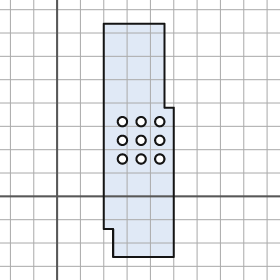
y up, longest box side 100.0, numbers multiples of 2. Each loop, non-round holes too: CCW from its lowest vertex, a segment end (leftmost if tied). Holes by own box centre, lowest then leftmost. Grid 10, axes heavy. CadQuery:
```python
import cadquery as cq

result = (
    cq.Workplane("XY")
    .moveTo(24.0, -26.0)
    .lineTo(50.0, -26.0)
    .lineTo(50.0, 38.0)
    .lineTo(46.0, 38.0)
    .lineTo(46.0, 74.0)
    .lineTo(20.0, 74.0)
    .lineTo(20.0, -14.0)
    .lineTo(24.0, -14.0)
    .close()
    .moveTo(28.0, 16.0)
    .circle(2.0)
    .moveTo(36.0, 16.0)
    .circle(2.0)
    .moveTo(44.0, 16.0)
    .circle(2.0)
    .moveTo(28.0, 24.0)
    .circle(2.0)
    .moveTo(36.0, 24.0)
    .circle(2.0)
    .moveTo(44.0, 24.0)
    .circle(2.0)
    .moveTo(28.0, 32.0)
    .circle(2.0)
    .moveTo(36.0, 32.0)
    .circle(2.0)
    .moveTo(44.0, 32.0)
    .circle(2.0)
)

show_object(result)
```